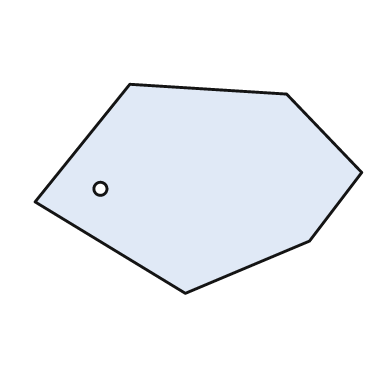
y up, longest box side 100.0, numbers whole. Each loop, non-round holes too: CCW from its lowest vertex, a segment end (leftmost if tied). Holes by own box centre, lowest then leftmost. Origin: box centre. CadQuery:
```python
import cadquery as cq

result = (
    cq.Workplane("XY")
    .moveTo(-4.0, -32.0)
    .lineTo(34.0, -16.0)
    .lineTo(50.0, 5.0)
    .lineTo(27.0, 29.0)
    .lineTo(-21.0, 32.0)
    .lineTo(-50.0, -4.0)
    .close()
    .moveTo(-30.0, 0.0)
    .circle(2.0)
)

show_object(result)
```